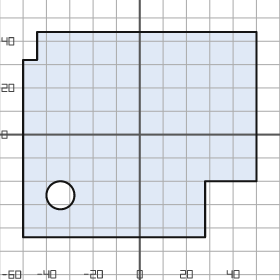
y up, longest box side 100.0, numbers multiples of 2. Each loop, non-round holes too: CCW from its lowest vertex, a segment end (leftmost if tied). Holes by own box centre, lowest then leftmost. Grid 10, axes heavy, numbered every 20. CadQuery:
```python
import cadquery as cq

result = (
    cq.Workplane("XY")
    .moveTo(-50.0, -44.0)
    .lineTo(28.0, -44.0)
    .lineTo(28.0, -20.0)
    .lineTo(50.0, -20.0)
    .lineTo(50.0, 44.0)
    .lineTo(-44.0, 44.0)
    .lineTo(-44.0, 32.0)
    .lineTo(-50.0, 32.0)
    .close()
    .moveTo(-34.0, -26.0)
    .circle(6.0)
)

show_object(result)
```